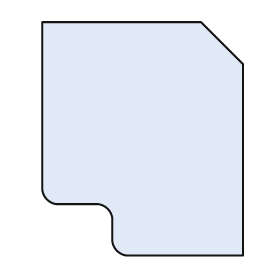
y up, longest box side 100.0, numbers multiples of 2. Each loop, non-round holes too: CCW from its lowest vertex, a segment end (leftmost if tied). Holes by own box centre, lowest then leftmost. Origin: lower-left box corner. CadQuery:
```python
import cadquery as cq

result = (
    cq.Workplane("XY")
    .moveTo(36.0, 0.0)
    .lineTo(86.0, 0.0)
    .lineTo(86.0, 82.0)
    .lineTo(68.0, 100.0)
    .lineTo(0.0, 100.0)
    .lineTo(0.0, 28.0)
    .threePointArc((2.0, 24.0), (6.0, 22.0))
    .lineTo(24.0, 22.0)
    .threePointArc((28.0, 20.0), (30.0, 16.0))
    .lineTo(30.0, 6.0)
    .threePointArc((32.0, 2.0), (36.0, 0.0))
    .close()
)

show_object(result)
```